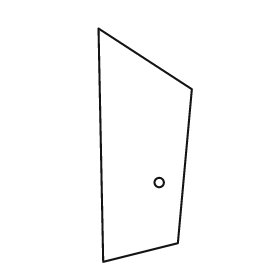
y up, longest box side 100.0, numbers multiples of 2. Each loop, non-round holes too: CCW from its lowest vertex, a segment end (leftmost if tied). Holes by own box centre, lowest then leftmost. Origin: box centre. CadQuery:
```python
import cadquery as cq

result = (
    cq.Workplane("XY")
    .moveTo(-18.0, -50.0)
    .lineTo(14.0, -42.0)
    .lineTo(20.0, 24.0)
    .lineTo(-20.0, 50.0)
    .close()
    .moveTo(6.0, -16.0)
    .circle(2.0)
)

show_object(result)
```